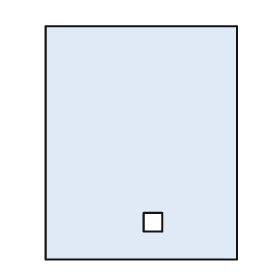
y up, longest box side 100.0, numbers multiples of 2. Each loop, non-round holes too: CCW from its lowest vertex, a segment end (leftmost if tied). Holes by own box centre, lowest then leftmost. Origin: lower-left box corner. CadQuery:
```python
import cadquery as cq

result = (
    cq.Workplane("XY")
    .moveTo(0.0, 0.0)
    .lineTo(82.0, 0.0)
    .lineTo(82.0, 100.0)
    .lineTo(0.0, 100.0)
    .close()
    .moveTo(42.0, 12.0)
    .lineTo(50.0, 12.0)
    .lineTo(50.0, 20.0)
    .lineTo(42.0, 20.0)
    .close()
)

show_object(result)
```